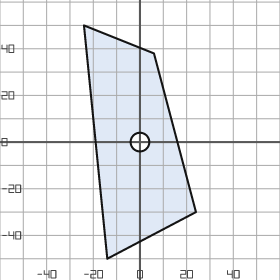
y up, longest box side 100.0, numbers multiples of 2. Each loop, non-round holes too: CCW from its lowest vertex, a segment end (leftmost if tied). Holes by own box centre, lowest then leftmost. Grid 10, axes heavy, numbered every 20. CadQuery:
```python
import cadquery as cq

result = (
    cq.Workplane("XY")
    .moveTo(-14.0, -50.0)
    .lineTo(24.0, -30.0)
    .lineTo(6.0, 38.0)
    .lineTo(-24.0, 50.0)
    .close()
    .moveTo(0.0, 0.0)
    .circle(4.0)
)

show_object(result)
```